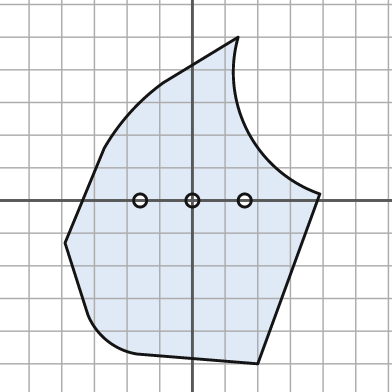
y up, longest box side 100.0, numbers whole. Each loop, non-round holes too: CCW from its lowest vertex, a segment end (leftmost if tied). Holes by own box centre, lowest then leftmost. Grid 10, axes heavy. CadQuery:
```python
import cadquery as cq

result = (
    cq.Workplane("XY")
    .moveTo(20.0, -50.0)
    .lineTo(39.0, 2.0)
    .threePointArc((17.0, 21.0), (14.0, 50.0))
    .lineTo(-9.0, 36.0)
    .threePointArc((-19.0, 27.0), (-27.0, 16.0))
    .lineTo(-39.0, -13.0)
    .lineTo(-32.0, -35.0)
    .threePointArc((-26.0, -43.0), (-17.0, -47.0))
    .close()
    .moveTo(-16.0, 0.0)
    .circle(2.0)
    .moveTo(0.0, 0.0)
    .circle(2.0)
    .moveTo(16.0, 0.0)
    .circle(2.0)
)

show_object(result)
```